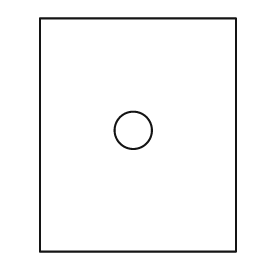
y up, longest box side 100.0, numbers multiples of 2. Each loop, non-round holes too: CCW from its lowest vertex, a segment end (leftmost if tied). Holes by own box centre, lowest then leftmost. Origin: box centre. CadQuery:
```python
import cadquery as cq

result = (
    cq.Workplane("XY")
    .moveTo(-42.0, -50.0)
    .lineTo(42.0, -50.0)
    .lineTo(42.0, 50.0)
    .lineTo(-42.0, 50.0)
    .close()
    .moveTo(-2.0, 2.0)
    .circle(8.0)
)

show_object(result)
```